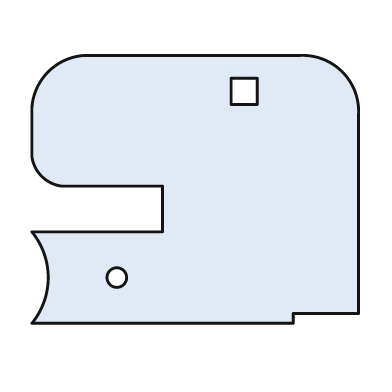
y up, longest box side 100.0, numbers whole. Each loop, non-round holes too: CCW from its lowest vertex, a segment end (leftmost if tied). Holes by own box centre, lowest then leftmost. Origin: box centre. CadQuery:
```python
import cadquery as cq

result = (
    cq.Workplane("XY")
    .moveTo(-50.0, -41.0)
    .lineTo(30.0, -41.0)
    .lineTo(30.0, -38.0)
    .lineTo(50.0, -38.0)
    .lineTo(50.0, 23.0)
    .threePointArc((45.0, 36.0), (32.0, 41.0))
    .lineTo(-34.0, 41.0)
    .threePointArc((-45.0, 36.0), (-50.0, 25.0))
    .lineTo(-50.0, 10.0)
    .threePointArc((-47.0, 4.0), (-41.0, 1.0))
    .lineTo(-10.0, 1.0)
    .lineTo(-10.0, -13.0)
    .lineTo(-50.0, -13.0)
    .threePointArc((-45.0, -27.0), (-50.0, -41.0))
    .close()
    .moveTo(-24.0, -27.0)
    .circle(3.0)
    .moveTo(11.0, 26.0)
    .lineTo(19.0, 26.0)
    .lineTo(19.0, 34.0)
    .lineTo(11.0, 34.0)
    .close()
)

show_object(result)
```